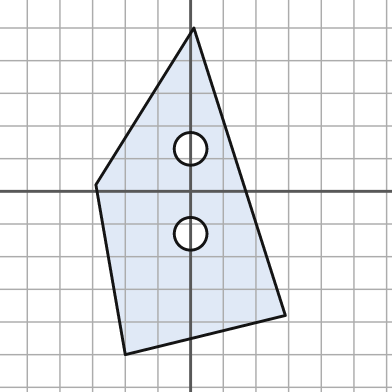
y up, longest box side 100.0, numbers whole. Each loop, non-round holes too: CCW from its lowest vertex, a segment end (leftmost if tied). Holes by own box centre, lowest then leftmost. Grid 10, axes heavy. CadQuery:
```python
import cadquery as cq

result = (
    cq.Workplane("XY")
    .moveTo(-20.0, -50.0)
    .lineTo(29.0, -38.0)
    .lineTo(1.0, 50.0)
    .lineTo(-29.0, 2.0)
    .close()
    .moveTo(0.0, -13.0)
    .circle(5.0)
    .moveTo(0.0, 13.0)
    .circle(5.0)
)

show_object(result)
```